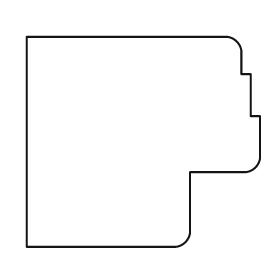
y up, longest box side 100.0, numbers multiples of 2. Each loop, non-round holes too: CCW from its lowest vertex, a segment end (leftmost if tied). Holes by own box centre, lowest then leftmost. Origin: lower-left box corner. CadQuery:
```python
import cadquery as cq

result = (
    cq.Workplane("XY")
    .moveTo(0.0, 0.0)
    .lineTo(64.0, 0.0)
    .threePointArc((68.0, 2.0), (70.0, 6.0))
    .lineTo(70.0, 32.0)
    .lineTo(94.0, 32.0)
    .threePointArc((98.0, 34.0), (100.0, 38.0))
    .lineTo(100.0, 56.0)
    .lineTo(96.0, 56.0)
    .lineTo(96.0, 74.0)
    .lineTo(92.0, 74.0)
    .lineTo(92.0, 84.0)
    .threePointArc((90.0, 88.0), (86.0, 90.0))
    .lineTo(0.0, 90.0)
    .close()
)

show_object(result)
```